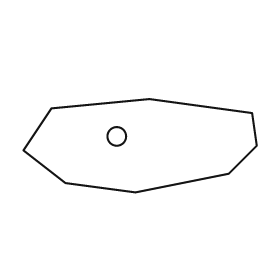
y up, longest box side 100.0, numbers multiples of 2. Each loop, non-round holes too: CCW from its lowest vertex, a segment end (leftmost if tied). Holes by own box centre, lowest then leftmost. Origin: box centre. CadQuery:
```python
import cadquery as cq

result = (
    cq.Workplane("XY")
    .moveTo(-2.0, -20.0)
    .lineTo(38.0, -12.0)
    .lineTo(50.0, 0.0)
    .lineTo(48.0, 14.0)
    .lineTo(4.0, 20.0)
    .lineTo(-38.0, 16.0)
    .lineTo(-50.0, -2.0)
    .lineTo(-32.0, -16.0)
    .close()
    .moveTo(-10.0, 4.0)
    .circle(4.0)
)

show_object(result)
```